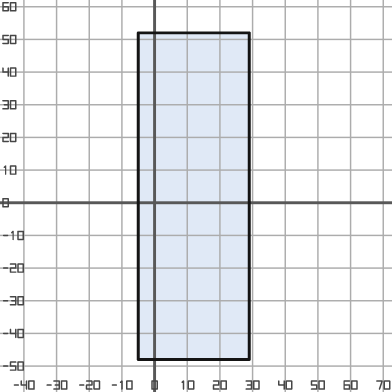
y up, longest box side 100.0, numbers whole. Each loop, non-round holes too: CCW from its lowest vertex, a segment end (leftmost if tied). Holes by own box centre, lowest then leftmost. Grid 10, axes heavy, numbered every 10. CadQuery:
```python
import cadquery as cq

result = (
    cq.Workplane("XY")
    .moveTo(-5.0, -48.0)
    .lineTo(29.0, -48.0)
    .lineTo(29.0, 52.0)
    .lineTo(-5.0, 52.0)
    .close()
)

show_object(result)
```